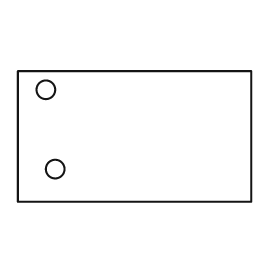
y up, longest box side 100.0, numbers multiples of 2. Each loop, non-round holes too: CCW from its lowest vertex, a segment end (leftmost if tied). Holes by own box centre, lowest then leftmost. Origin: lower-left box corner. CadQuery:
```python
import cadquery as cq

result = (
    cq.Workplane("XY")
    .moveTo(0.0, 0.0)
    .lineTo(100.0, 0.0)
    .lineTo(100.0, 56.0)
    .lineTo(0.0, 56.0)
    .close()
    .moveTo(16.0, 14.0)
    .circle(4.0)
    .moveTo(12.0, 48.0)
    .circle(4.0)
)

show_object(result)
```